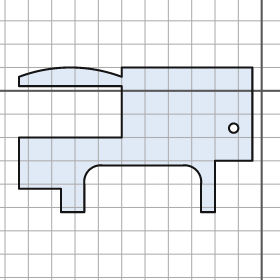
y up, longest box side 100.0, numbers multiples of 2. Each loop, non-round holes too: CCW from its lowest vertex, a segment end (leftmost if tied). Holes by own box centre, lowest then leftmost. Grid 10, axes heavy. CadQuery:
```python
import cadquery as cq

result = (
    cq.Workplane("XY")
    .moveTo(-86.0, -52.0)
    .lineTo(-76.0, -52.0)
    .lineTo(-76.0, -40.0)
    .threePointArc((-74.0, -34.0), (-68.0, -32.0))
    .lineTo(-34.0, -32.0)
    .threePointArc((-28.0, -34.0), (-26.0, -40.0))
    .lineTo(-26.0, -52.0)
    .lineTo(-20.0, -52.0)
    .lineTo(-20.0, -30.0)
    .lineTo(-4.0, -30.0)
    .lineTo(-4.0, 10.0)
    .lineTo(-60.0, 10.0)
    .lineTo(-60.0, 6.0)
    .threePointArc((-82.0, 10.0), (-104.0, 6.0))
    .lineTo(-104.0, 2.0)
    .lineTo(-60.0, 2.0)
    .lineTo(-60.0, -20.0)
    .lineTo(-104.0, -20.0)
    .lineTo(-104.0, -42.0)
    .lineTo(-86.0, -42.0)
    .close()
    .moveTo(-12.0, -16.0)
    .circle(2.0)
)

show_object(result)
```